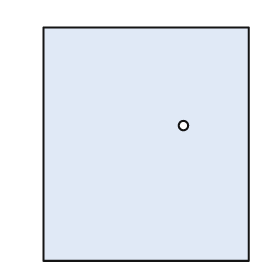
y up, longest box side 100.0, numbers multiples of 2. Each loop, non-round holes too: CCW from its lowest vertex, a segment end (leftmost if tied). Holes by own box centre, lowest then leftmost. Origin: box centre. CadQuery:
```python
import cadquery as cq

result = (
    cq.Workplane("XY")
    .moveTo(-44.0, -50.0)
    .lineTo(44.0, -50.0)
    .lineTo(44.0, 50.0)
    .lineTo(-44.0, 50.0)
    .close()
    .moveTo(16.0, 8.0)
    .circle(2.0)
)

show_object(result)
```